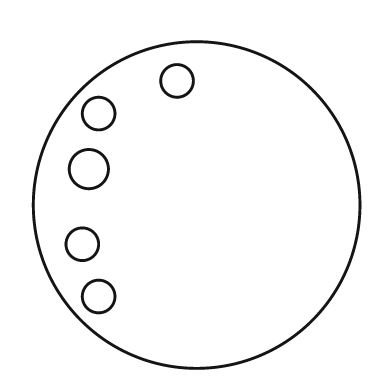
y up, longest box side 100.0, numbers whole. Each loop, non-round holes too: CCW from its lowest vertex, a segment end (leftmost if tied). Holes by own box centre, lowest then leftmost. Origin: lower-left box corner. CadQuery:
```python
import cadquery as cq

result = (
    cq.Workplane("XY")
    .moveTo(50.0, 50.0)
    .circle(50.0)
    .moveTo(20.0, 22.0)
    .circle(5.0)
    .moveTo(15.0, 38.0)
    .circle(5.0)
    .moveTo(17.0, 61.0)
    .circle(6.0)
    .moveTo(20.0, 78.0)
    .circle(5.0)
    .moveTo(44.0, 88.0)
    .circle(5.0)
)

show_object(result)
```